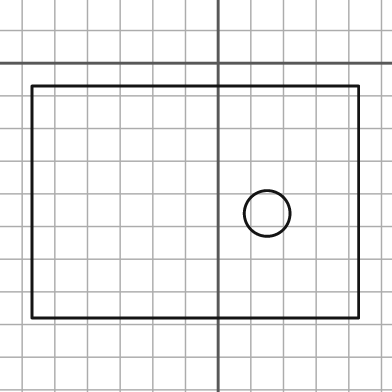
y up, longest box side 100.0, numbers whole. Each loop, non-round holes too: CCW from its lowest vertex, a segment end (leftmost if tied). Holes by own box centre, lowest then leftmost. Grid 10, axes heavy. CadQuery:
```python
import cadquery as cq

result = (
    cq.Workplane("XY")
    .moveTo(-57.0, -78.0)
    .lineTo(43.0, -78.0)
    .lineTo(43.0, -7.0)
    .lineTo(-57.0, -7.0)
    .close()
    .moveTo(15.0, -46.0)
    .circle(7.0)
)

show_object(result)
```